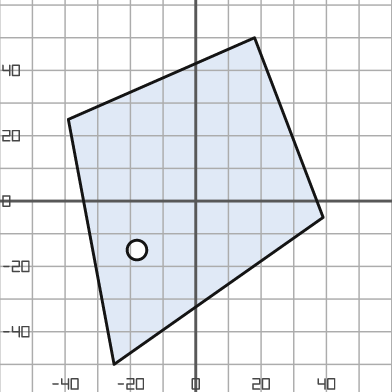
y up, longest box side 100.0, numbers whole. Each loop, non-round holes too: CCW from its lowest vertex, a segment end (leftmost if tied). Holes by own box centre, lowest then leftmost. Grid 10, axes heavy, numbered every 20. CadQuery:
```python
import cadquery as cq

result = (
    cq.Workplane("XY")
    .moveTo(-25.0, -50.0)
    .lineTo(39.0, -5.0)
    .lineTo(18.0, 50.0)
    .lineTo(-39.0, 25.0)
    .close()
    .moveTo(-18.0, -15.0)
    .circle(3.0)
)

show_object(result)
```